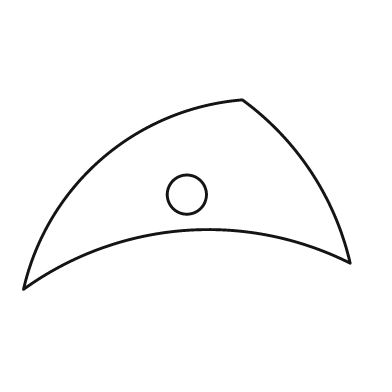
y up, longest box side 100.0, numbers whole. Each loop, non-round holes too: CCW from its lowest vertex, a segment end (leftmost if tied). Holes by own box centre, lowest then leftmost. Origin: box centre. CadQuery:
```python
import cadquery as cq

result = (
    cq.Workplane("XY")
    .moveTo(-50.0, -29.0)
    .threePointArc((-1.0, -11.0), (50.0, -21.0))
    .threePointArc((38.0, 7.0), (17.0, 29.0))
    .threePointArc((-26.0, 11.0), (-50.0, -29.0))
    .close()
    .moveTo(0.0, 0.0)
    .circle(6.0)
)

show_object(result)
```